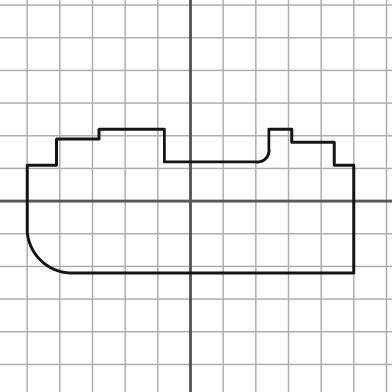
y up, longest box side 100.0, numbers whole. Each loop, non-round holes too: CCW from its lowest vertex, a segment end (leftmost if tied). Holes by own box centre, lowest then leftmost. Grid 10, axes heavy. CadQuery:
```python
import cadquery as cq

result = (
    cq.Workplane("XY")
    .moveTo(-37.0, -22.0)
    .lineTo(50.0, -22.0)
    .lineTo(50.0, 11.0)
    .lineTo(44.0, 11.0)
    .lineTo(44.0, 18.0)
    .lineTo(31.0, 18.0)
    .lineTo(31.0, 22.0)
    .lineTo(24.0, 22.0)
    .lineTo(24.0, 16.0)
    .threePointArc((23.0, 13.0), (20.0, 12.0))
    .lineTo(-8.0, 12.0)
    .lineTo(-8.0, 22.0)
    .lineTo(-28.0, 22.0)
    .lineTo(-28.0, 19.0)
    .lineTo(-41.0, 19.0)
    .lineTo(-41.0, 11.0)
    .lineTo(-50.0, 11.0)
    .lineTo(-50.0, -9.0)
    .threePointArc((-46.0, -18.0), (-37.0, -22.0))
    .close()
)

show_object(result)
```